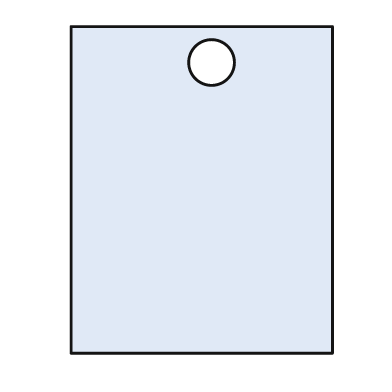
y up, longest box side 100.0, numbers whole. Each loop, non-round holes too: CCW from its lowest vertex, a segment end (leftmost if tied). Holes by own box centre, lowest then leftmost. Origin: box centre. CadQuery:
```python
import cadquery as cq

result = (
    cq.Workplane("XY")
    .moveTo(-40.0, -50.0)
    .lineTo(40.0, -50.0)
    .lineTo(40.0, 50.0)
    .lineTo(-40.0, 50.0)
    .close()
    .moveTo(3.0, 39.0)
    .circle(7.0)
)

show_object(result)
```